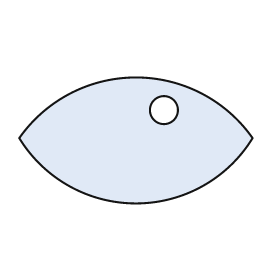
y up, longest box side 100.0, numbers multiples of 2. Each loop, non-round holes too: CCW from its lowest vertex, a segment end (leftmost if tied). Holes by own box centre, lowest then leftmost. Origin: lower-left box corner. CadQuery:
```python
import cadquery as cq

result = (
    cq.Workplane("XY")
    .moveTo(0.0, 28.0)
    .threePointArc((50.0, 0.0), (100.0, 28.0))
    .threePointArc((50.0, 54.0), (0.0, 28.0))
    .close()
    .moveTo(62.0, 40.0)
    .circle(6.0)
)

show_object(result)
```